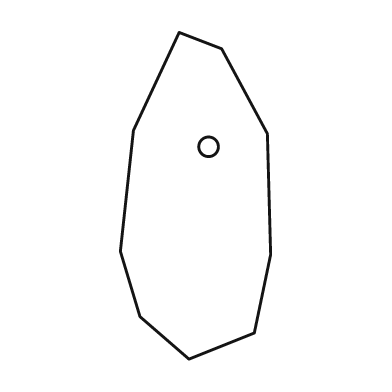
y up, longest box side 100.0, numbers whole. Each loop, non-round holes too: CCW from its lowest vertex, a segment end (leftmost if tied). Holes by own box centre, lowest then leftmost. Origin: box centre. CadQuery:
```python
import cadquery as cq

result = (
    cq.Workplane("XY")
    .moveTo(-2.0, -50.0)
    .lineTo(18.0, -42.0)
    .lineTo(23.0, -18.0)
    .lineTo(22.0, 19.0)
    .lineTo(8.0, 45.0)
    .lineTo(-5.0, 50.0)
    .lineTo(-19.0, 20.0)
    .lineTo(-23.0, -17.0)
    .lineTo(-17.0, -37.0)
    .close()
    .moveTo(4.0, 15.0)
    .circle(3.0)
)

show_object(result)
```